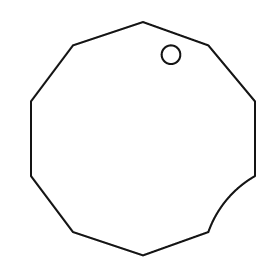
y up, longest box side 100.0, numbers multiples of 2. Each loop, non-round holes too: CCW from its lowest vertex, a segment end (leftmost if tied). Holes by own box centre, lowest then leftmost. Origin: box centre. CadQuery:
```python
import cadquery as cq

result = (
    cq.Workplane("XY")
    .moveTo(0.0, -50.0)
    .lineTo(28.0, -40.0)
    .threePointArc((36.0, -26.0), (48.0, -16.0))
    .lineTo(48.0, 16.0)
    .lineTo(28.0, 40.0)
    .lineTo(0.0, 50.0)
    .lineTo(-30.0, 40.0)
    .lineTo(-48.0, 16.0)
    .lineTo(-48.0, -16.0)
    .lineTo(-30.0, -40.0)
    .close()
    .moveTo(12.0, 36.0)
    .circle(4.0)
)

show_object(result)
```